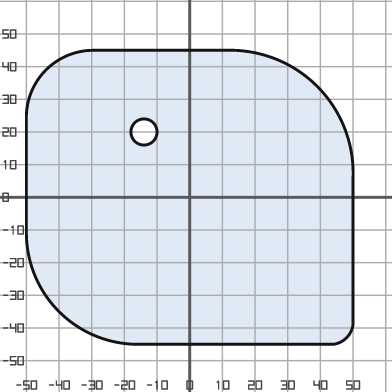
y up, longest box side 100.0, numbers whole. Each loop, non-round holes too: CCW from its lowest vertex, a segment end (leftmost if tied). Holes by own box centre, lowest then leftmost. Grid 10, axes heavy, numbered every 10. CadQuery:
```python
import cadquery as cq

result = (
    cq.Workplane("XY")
    .moveTo(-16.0, -45.0)
    .lineTo(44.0, -45.0)
    .threePointArc((48.0, -43.0), (50.0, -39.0))
    .lineTo(50.0, 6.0)
    .threePointArc((39.0, 34.0), (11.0, 45.0))
    .lineTo(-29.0, 45.0)
    .threePointArc((-44.0, 39.0), (-50.0, 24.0))
    .lineTo(-50.0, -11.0)
    .threePointArc((-40.0, -35.0), (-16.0, -45.0))
    .close()
    .moveTo(-14.0, 20.0)
    .circle(4.0)
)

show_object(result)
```